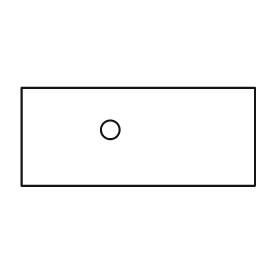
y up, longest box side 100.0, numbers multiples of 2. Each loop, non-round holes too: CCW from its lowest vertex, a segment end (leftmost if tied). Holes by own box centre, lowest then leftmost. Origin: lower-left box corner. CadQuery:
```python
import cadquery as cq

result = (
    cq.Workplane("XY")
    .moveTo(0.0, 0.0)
    .lineTo(100.0, 0.0)
    .lineTo(100.0, 42.0)
    .lineTo(0.0, 42.0)
    .close()
    .moveTo(38.0, 24.0)
    .circle(4.0)
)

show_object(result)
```